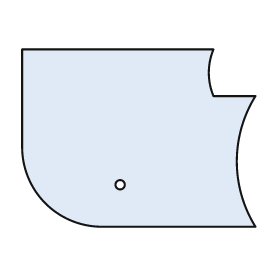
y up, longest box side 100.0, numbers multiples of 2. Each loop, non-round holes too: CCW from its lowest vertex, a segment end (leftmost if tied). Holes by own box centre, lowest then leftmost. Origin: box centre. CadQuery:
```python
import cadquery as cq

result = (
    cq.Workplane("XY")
    .moveTo(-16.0, -38.0)
    .lineTo(50.0, -38.0)
    .threePointArc((42.0, -10.0), (50.0, 18.0))
    .lineTo(32.0, 18.0)
    .threePointArc((30.0, 28.0), (32.0, 38.0))
    .lineTo(-50.0, 38.0)
    .lineTo(-50.0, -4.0)
    .threePointArc((-40.0, -28.0), (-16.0, -38.0))
    .close()
    .moveTo(-8.0, -20.0)
    .circle(2.0)
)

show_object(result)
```